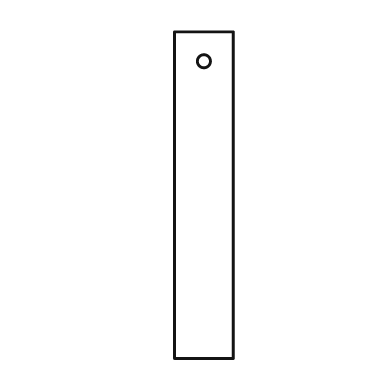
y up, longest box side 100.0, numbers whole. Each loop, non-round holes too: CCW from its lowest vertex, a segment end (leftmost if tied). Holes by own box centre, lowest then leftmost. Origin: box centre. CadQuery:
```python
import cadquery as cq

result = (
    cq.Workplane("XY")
    .moveTo(-9.0, -50.0)
    .lineTo(9.0, -50.0)
    .lineTo(9.0, 50.0)
    .lineTo(-9.0, 50.0)
    .close()
    .moveTo(0.0, 41.0)
    .circle(2.0)
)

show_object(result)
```